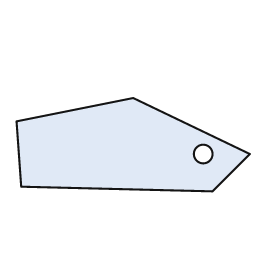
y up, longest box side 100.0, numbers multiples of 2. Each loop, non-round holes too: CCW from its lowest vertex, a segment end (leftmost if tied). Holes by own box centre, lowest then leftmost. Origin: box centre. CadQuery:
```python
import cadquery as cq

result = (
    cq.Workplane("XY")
    .moveTo(34.0, -20.0)
    .lineTo(50.0, -4.0)
    .lineTo(0.0, 20.0)
    .lineTo(-50.0, 10.0)
    .lineTo(-48.0, -18.0)
    .close()
    .moveTo(30.0, -4.0)
    .circle(4.0)
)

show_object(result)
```